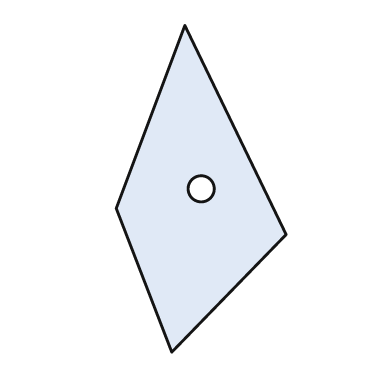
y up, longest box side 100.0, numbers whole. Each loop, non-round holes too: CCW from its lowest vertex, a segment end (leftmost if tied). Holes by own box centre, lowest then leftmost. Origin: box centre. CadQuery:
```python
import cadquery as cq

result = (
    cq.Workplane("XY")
    .moveTo(-9.0, -50.0)
    .lineTo(26.0, -14.0)
    .lineTo(-5.0, 50.0)
    .lineTo(-26.0, -6.0)
    .close()
    .moveTo(0.0, 0.0)
    .circle(4.0)
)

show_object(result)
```